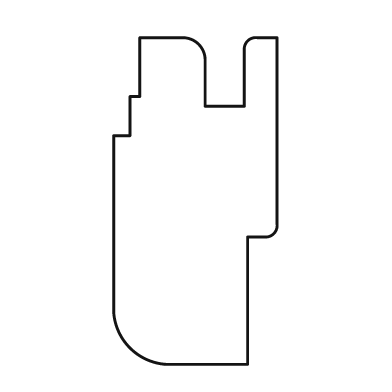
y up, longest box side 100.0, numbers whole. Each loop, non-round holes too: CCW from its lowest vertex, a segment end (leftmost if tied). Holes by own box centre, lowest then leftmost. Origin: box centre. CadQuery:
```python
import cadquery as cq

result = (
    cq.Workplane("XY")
    .moveTo(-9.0, -50.0)
    .lineTo(16.0, -50.0)
    .lineTo(16.0, -11.0)
    .lineTo(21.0, -11.0)
    .threePointArc((24.0, -10.0), (25.0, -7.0))
    .lineTo(25.0, 50.0)
    .lineTo(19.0, 50.0)
    .threePointArc((16.0, 49.0), (15.0, 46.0))
    .lineTo(15.0, 29.0)
    .lineTo(3.0, 29.0)
    .lineTo(3.0, 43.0)
    .threePointArc((1.0, 48.0), (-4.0, 50.0))
    .lineTo(-17.0, 50.0)
    .lineTo(-17.0, 32.0)
    .lineTo(-20.0, 32.0)
    .lineTo(-20.0, 20.0)
    .lineTo(-25.0, 20.0)
    .lineTo(-25.0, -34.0)
    .threePointArc((-20.0, -45.0), (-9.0, -50.0))
    .close()
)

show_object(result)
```